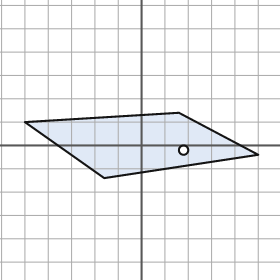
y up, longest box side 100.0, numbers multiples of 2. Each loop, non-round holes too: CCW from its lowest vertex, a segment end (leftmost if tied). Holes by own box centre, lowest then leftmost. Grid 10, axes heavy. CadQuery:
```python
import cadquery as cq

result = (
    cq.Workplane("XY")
    .moveTo(-16.0, -14.0)
    .lineTo(50.0, -4.0)
    .lineTo(16.0, 14.0)
    .lineTo(-50.0, 10.0)
    .close()
    .moveTo(18.0, -2.0)
    .circle(2.0)
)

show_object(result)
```